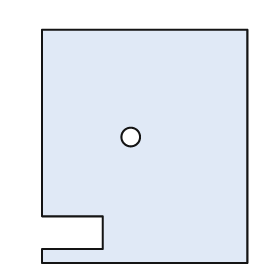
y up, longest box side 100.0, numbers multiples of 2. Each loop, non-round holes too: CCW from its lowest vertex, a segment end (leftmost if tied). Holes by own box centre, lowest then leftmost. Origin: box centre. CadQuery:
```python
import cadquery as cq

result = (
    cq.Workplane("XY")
    .moveTo(-44.0, -50.0)
    .lineTo(44.0, -50.0)
    .lineTo(44.0, 50.0)
    .lineTo(-44.0, 50.0)
    .lineTo(-44.0, -30.0)
    .lineTo(-18.0, -30.0)
    .lineTo(-18.0, -44.0)
    .lineTo(-44.0, -44.0)
    .close()
    .moveTo(-6.0, 4.0)
    .circle(4.0)
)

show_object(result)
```